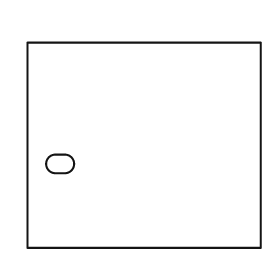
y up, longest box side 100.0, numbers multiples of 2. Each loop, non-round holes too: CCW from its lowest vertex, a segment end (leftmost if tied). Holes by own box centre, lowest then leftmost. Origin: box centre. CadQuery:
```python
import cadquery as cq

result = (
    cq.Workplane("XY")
    .moveTo(-50.0, -44.0)
    .lineTo(50.0, -44.0)
    .lineTo(50.0, 44.0)
    .lineTo(-50.0, 44.0)
    .close()
    .moveTo(-38.0, -12.0)
    .lineTo(-34.0, -12.0)
    .threePointArc((-30.0, -8.0), (-34.0, -4.0))
    .lineTo(-38.0, -4.0)
    .threePointArc((-42.0, -8.0), (-38.0, -12.0))
    .close()
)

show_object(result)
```